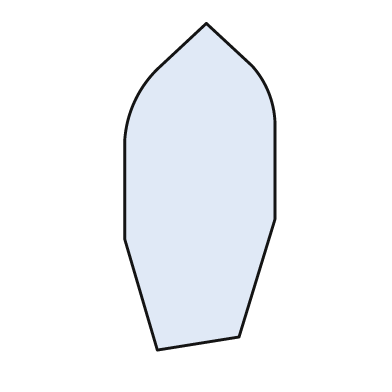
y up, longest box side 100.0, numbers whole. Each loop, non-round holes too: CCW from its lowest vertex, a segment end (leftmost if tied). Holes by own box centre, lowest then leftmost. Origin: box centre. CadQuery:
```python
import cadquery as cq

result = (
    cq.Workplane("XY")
    .moveTo(-13.0, -50.0)
    .lineTo(12.0, -46.0)
    .lineTo(23.0, -10.0)
    .lineTo(23.0, 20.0)
    .threePointArc((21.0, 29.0), (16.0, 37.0))
    .lineTo(2.0, 50.0)
    .lineTo(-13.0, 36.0)
    .threePointArc((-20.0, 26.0), (-23.0, 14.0))
    .lineTo(-23.0, -16.0)
    .close()
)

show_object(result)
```